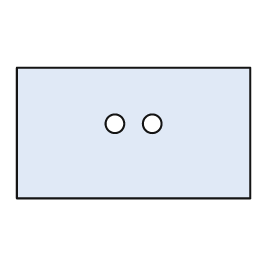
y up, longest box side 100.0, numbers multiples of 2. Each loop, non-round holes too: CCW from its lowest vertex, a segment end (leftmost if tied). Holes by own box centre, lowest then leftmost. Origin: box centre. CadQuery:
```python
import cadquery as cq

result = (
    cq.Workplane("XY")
    .moveTo(-50.0, -28.0)
    .lineTo(50.0, -28.0)
    .lineTo(50.0, 28.0)
    .lineTo(-50.0, 28.0)
    .close()
    .moveTo(-8.0, 4.0)
    .circle(4.0)
    .moveTo(8.0, 4.0)
    .circle(4.0)
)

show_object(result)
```